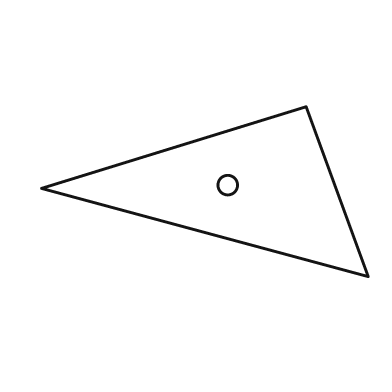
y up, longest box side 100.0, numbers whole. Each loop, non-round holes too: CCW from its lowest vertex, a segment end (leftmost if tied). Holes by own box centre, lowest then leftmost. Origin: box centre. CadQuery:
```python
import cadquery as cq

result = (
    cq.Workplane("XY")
    .moveTo(50.0, -26.0)
    .lineTo(31.0, 26.0)
    .lineTo(-50.0, 1.0)
    .close()
    .moveTo(7.0, 2.0)
    .circle(3.0)
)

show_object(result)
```